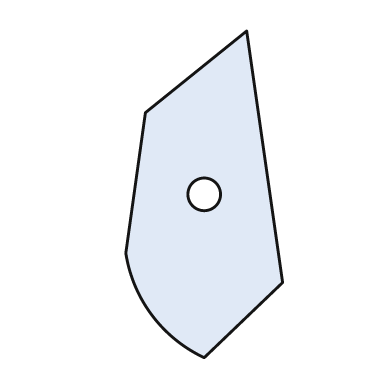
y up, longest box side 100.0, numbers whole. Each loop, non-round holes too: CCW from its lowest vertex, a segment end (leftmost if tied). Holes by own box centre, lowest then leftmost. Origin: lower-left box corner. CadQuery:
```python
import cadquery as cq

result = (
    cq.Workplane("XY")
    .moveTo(24.0, 0.0)
    .lineTo(48.0, 23.0)
    .lineTo(37.0, 100.0)
    .lineTo(6.0, 75.0)
    .lineTo(0.0, 32.0)
    .threePointArc((8.0, 13.0), (24.0, 0.0))
    .close()
    .moveTo(24.0, 50.0)
    .circle(5.0)
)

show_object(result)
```